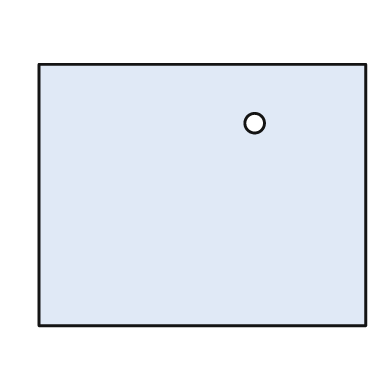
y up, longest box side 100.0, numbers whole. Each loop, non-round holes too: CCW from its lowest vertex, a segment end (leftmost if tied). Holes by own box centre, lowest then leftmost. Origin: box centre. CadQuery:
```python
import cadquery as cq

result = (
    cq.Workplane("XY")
    .moveTo(-50.0, -40.0)
    .lineTo(50.0, -40.0)
    .lineTo(50.0, 40.0)
    .lineTo(-50.0, 40.0)
    .close()
    .moveTo(16.0, 22.0)
    .circle(3.0)
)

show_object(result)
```